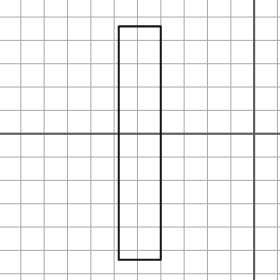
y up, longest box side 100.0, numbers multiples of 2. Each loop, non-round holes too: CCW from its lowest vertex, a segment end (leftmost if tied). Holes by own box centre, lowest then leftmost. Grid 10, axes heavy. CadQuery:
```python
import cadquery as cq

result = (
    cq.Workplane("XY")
    .moveTo(-58.0, -54.0)
    .lineTo(-40.0, -54.0)
    .lineTo(-40.0, 46.0)
    .lineTo(-58.0, 46.0)
    .close()
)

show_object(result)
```